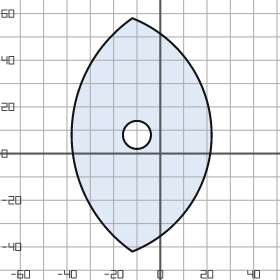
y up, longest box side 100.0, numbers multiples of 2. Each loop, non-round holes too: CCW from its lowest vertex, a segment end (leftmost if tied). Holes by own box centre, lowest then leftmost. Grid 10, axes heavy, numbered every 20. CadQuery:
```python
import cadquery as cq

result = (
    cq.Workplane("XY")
    .moveTo(-12.0, -42.0)
    .threePointArc((22.0, 8.0), (-12.0, 58.0))
    .threePointArc((-38.0, 8.0), (-12.0, -42.0))
    .close()
    .moveTo(-10.0, 8.0)
    .circle(6.0)
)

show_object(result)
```